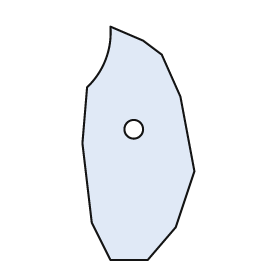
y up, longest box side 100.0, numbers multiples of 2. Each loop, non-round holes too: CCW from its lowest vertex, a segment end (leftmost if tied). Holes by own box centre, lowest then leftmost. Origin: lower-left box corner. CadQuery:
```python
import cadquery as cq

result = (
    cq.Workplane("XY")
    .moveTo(12.0, 0.0)
    .lineTo(28.0, 0.0)
    .lineTo(40.0, 14.0)
    .lineTo(48.0, 38.0)
    .lineTo(42.0, 70.0)
    .lineTo(34.0, 88.0)
    .lineTo(26.0, 94.0)
    .lineTo(12.0, 100.0)
    .threePointArc((10.0, 86.0), (2.0, 74.0))
    .lineTo(0.0, 50.0)
    .lineTo(4.0, 16.0)
    .close()
    .moveTo(22.0, 56.0)
    .circle(4.0)
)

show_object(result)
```